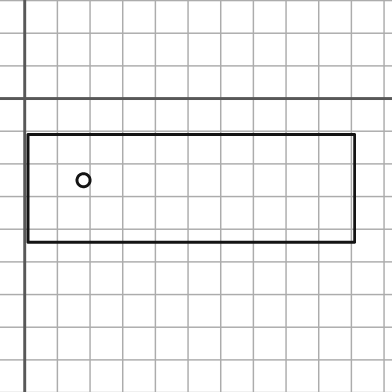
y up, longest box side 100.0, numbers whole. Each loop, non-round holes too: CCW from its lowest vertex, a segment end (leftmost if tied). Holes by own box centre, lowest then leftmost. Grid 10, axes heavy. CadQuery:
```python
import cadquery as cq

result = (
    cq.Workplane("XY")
    .moveTo(1.0, -44.0)
    .lineTo(101.0, -44.0)
    .lineTo(101.0, -11.0)
    .lineTo(1.0, -11.0)
    .close()
    .moveTo(18.0, -25.0)
    .circle(2.0)
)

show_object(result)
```